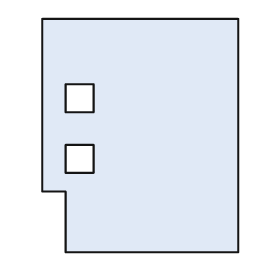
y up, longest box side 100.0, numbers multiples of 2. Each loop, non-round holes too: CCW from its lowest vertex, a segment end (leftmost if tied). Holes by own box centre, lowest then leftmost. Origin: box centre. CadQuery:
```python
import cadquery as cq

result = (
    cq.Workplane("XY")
    .moveTo(-32.0, -50.0)
    .lineTo(42.0, -50.0)
    .lineTo(42.0, 50.0)
    .lineTo(-42.0, 50.0)
    .lineTo(-42.0, -24.0)
    .lineTo(-32.0, -24.0)
    .close()
    .moveTo(-32.0, -16.0)
    .lineTo(-20.0, -16.0)
    .lineTo(-20.0, -4.0)
    .lineTo(-32.0, -4.0)
    .close()
    .moveTo(-32.0, 10.0)
    .lineTo(-20.0, 10.0)
    .lineTo(-20.0, 22.0)
    .lineTo(-32.0, 22.0)
    .close()
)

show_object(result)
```